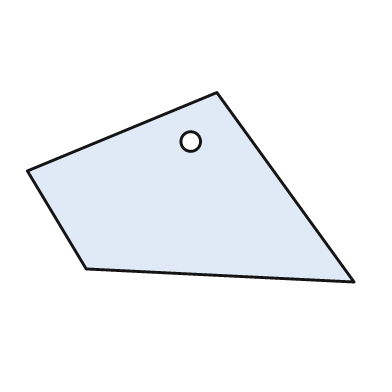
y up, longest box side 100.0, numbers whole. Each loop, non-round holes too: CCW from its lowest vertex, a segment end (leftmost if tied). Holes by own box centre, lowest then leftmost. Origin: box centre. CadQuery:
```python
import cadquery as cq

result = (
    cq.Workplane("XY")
    .moveTo(50.0, -29.0)
    .lineTo(8.0, 29.0)
    .lineTo(-50.0, 5.0)
    .lineTo(-32.0, -25.0)
    .close()
    .moveTo(0.0, 14.0)
    .circle(3.0)
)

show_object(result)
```